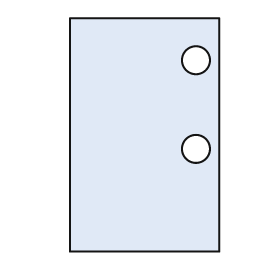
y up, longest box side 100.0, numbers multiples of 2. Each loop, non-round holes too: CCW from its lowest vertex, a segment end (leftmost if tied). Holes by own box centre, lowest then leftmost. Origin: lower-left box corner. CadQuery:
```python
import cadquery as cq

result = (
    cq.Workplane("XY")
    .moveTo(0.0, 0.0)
    .lineTo(64.0, 0.0)
    .lineTo(64.0, 100.0)
    .lineTo(0.0, 100.0)
    .close()
    .moveTo(54.0, 44.0)
    .circle(6.0)
    .moveTo(54.0, 82.0)
    .circle(6.0)
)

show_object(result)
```